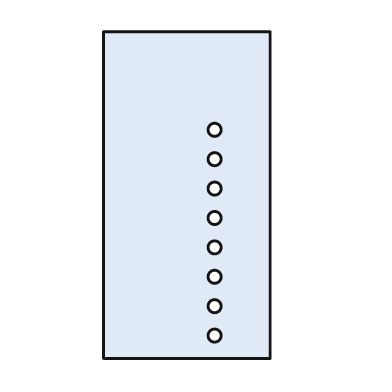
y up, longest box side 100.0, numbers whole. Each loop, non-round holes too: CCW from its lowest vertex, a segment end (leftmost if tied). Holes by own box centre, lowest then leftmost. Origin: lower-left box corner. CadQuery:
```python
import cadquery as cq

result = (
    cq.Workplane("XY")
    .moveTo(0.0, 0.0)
    .lineTo(51.0, 0.0)
    .lineTo(51.0, 100.0)
    .lineTo(0.0, 100.0)
    .close()
    .moveTo(34.0, 7.0)
    .circle(2.0)
    .moveTo(34.0, 16.0)
    .circle(2.0)
    .moveTo(34.0, 25.0)
    .circle(2.0)
    .moveTo(34.0, 34.0)
    .circle(2.0)
    .moveTo(34.0, 43.0)
    .circle(2.0)
    .moveTo(34.0, 52.0)
    .circle(2.0)
    .moveTo(34.0, 61.0)
    .circle(2.0)
    .moveTo(34.0, 70.0)
    .circle(2.0)
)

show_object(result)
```